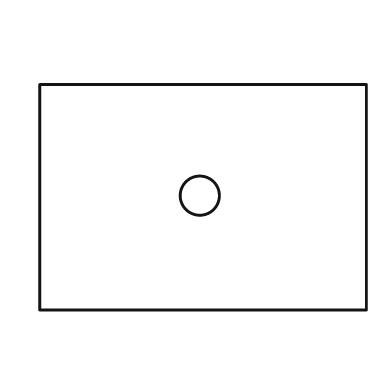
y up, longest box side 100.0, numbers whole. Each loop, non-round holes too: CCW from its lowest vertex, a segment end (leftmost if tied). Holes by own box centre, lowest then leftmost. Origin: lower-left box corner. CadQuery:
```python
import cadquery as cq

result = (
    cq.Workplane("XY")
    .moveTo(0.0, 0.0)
    .lineTo(100.0, 0.0)
    .lineTo(100.0, 69.0)
    .lineTo(0.0, 69.0)
    .close()
    .moveTo(49.0, 35.0)
    .circle(6.0)
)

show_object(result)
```